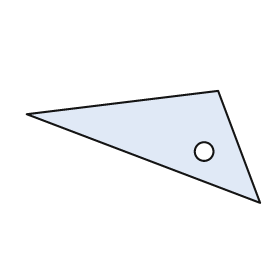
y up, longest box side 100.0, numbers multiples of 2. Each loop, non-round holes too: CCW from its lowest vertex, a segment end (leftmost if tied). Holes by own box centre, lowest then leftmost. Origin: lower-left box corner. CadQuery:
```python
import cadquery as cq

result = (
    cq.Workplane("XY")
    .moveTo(100.0, 0.0)
    .lineTo(82.0, 48.0)
    .lineTo(0.0, 38.0)
    .close()
    .moveTo(76.0, 22.0)
    .circle(4.0)
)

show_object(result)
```